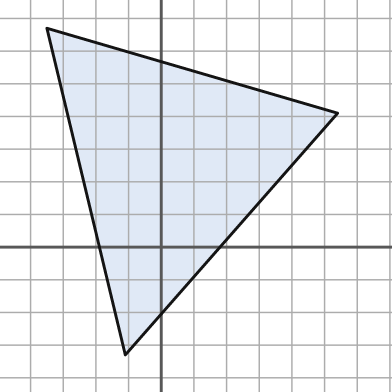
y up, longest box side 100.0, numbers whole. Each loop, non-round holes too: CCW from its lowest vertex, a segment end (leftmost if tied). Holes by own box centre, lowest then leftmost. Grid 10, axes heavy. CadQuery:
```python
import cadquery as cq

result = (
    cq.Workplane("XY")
    .moveTo(-11.0, -33.0)
    .lineTo(54.0, 41.0)
    .lineTo(-35.0, 67.0)
    .close()
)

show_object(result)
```